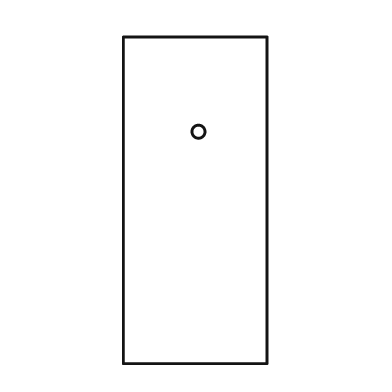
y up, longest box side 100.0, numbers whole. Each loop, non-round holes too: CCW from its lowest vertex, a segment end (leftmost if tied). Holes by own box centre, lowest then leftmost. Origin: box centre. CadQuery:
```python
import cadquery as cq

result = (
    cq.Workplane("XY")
    .moveTo(-22.0, -50.0)
    .lineTo(22.0, -50.0)
    .lineTo(22.0, 50.0)
    .lineTo(-22.0, 50.0)
    .close()
    .moveTo(1.0, 21.0)
    .circle(2.0)
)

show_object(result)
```